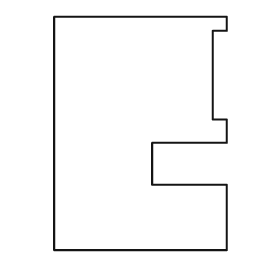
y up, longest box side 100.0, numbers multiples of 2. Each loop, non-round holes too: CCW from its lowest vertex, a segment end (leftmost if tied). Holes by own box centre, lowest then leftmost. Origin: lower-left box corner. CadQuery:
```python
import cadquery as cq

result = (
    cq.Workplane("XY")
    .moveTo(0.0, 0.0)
    .lineTo(74.0, 0.0)
    .lineTo(74.0, 28.0)
    .lineTo(42.0, 28.0)
    .lineTo(42.0, 46.0)
    .lineTo(74.0, 46.0)
    .lineTo(74.0, 56.0)
    .lineTo(68.0, 56.0)
    .lineTo(68.0, 94.0)
    .lineTo(74.0, 94.0)
    .lineTo(74.0, 100.0)
    .lineTo(0.0, 100.0)
    .close()
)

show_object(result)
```